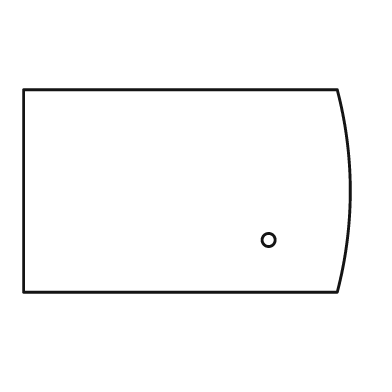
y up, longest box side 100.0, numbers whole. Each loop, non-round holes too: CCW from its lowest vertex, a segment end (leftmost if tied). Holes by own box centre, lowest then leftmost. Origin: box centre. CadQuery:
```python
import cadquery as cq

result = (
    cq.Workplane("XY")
    .moveTo(-50.0, -31.0)
    .lineTo(46.0, -31.0)
    .threePointArc((50.0, 0.0), (46.0, 31.0))
    .lineTo(-50.0, 31.0)
    .close()
    .moveTo(25.0, -15.0)
    .circle(2.0)
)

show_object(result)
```